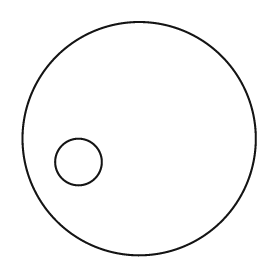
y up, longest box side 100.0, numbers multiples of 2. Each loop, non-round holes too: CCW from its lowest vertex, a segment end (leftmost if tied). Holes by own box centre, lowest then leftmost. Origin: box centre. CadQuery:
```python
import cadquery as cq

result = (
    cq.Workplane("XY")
    .moveTo(0.0, 0.0)
    .circle(50.0)
    .moveTo(-26.0, -10.0)
    .circle(10.0)
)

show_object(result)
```